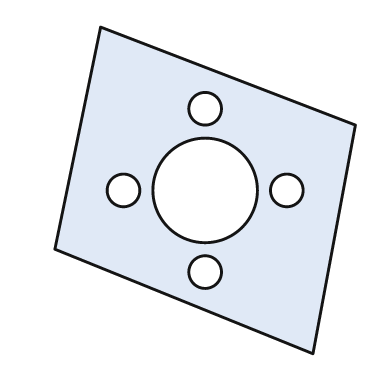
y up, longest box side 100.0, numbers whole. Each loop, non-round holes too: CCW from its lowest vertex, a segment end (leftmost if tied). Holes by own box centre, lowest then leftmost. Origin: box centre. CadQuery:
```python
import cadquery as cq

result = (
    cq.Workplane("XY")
    .moveTo(33.0, -50.0)
    .lineTo(46.0, 20.0)
    .lineTo(-32.0, 50.0)
    .lineTo(-46.0, -18.0)
    .close()
    .moveTo(0.0, -25.0)
    .circle(5.0)
    .moveTo(-25.0, 0.0)
    .circle(5.0)
    .moveTo(0.0, 0.0)
    .circle(16.0)
    .moveTo(25.0, 0.0)
    .circle(5.0)
    .moveTo(0.0, 25.0)
    .circle(5.0)
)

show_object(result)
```